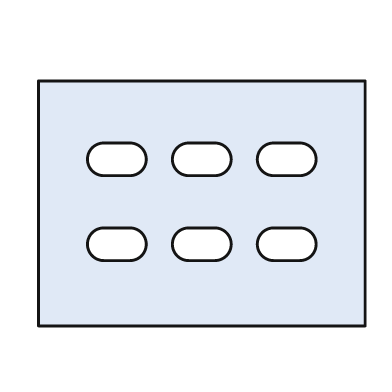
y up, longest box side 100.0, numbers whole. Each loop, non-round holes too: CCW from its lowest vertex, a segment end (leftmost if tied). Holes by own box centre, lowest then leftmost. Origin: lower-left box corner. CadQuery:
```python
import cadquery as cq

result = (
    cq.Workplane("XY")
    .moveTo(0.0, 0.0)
    .lineTo(100.0, 0.0)
    .lineTo(100.0, 75.0)
    .lineTo(0.0, 75.0)
    .close()
    .moveTo(20.0, 20.0)
    .lineTo(28.0, 20.0)
    .threePointArc((33.0, 25.0), (28.0, 30.0))
    .lineTo(20.0, 30.0)
    .threePointArc((15.0, 25.0), (20.0, 20.0))
    .close()
    .moveTo(46.0, 20.0)
    .lineTo(54.0, 20.0)
    .threePointArc((59.0, 25.0), (54.0, 30.0))
    .lineTo(46.0, 30.0)
    .threePointArc((41.0, 25.0), (46.0, 20.0))
    .close()
    .moveTo(72.0, 20.0)
    .lineTo(80.0, 20.0)
    .threePointArc((85.0, 25.0), (80.0, 30.0))
    .lineTo(72.0, 30.0)
    .threePointArc((67.0, 25.0), (72.0, 20.0))
    .close()
    .moveTo(20.0, 46.0)
    .lineTo(28.0, 46.0)
    .threePointArc((33.0, 51.0), (28.0, 56.0))
    .lineTo(20.0, 56.0)
    .threePointArc((15.0, 51.0), (20.0, 46.0))
    .close()
    .moveTo(46.0, 46.0)
    .lineTo(54.0, 46.0)
    .threePointArc((59.0, 51.0), (54.0, 56.0))
    .lineTo(46.0, 56.0)
    .threePointArc((41.0, 51.0), (46.0, 46.0))
    .close()
    .moveTo(72.0, 46.0)
    .lineTo(80.0, 46.0)
    .threePointArc((85.0, 51.0), (80.0, 56.0))
    .lineTo(72.0, 56.0)
    .threePointArc((67.0, 51.0), (72.0, 46.0))
    .close()
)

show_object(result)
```